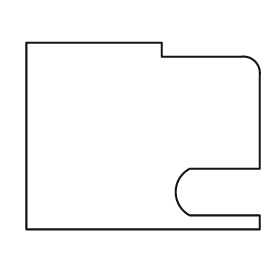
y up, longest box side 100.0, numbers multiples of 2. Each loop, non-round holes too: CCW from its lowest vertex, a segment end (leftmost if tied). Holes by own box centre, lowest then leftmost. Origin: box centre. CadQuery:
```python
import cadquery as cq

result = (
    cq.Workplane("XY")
    .moveTo(-50.0, -40.0)
    .lineTo(50.0, -40.0)
    .lineTo(50.0, -34.0)
    .lineTo(20.0, -34.0)
    .threePointArc((14.0, -24.0), (20.0, -14.0))
    .lineTo(50.0, -14.0)
    .lineTo(50.0, 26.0)
    .threePointArc((48.0, 32.0), (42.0, 34.0))
    .lineTo(8.0, 34.0)
    .lineTo(8.0, 40.0)
    .lineTo(-50.0, 40.0)
    .close()
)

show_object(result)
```